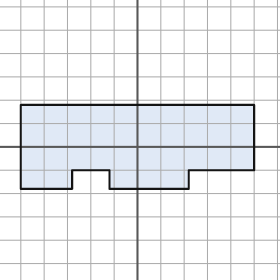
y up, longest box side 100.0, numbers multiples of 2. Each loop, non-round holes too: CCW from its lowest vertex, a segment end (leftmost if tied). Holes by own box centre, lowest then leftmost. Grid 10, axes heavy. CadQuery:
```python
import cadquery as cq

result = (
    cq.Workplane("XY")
    .moveTo(-50.0, -18.0)
    .lineTo(-28.0, -18.0)
    .lineTo(-28.0, -10.0)
    .lineTo(-12.0, -10.0)
    .lineTo(-12.0, -18.0)
    .lineTo(22.0, -18.0)
    .lineTo(22.0, -10.0)
    .lineTo(50.0, -10.0)
    .lineTo(50.0, 18.0)
    .lineTo(-50.0, 18.0)
    .close()
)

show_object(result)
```